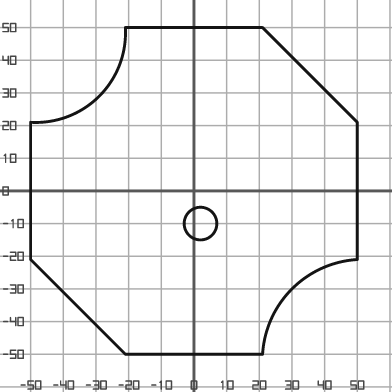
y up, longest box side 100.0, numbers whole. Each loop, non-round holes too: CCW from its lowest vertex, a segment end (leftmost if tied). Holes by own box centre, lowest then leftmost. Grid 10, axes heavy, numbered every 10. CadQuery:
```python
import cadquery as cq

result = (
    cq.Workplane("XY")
    .moveTo(-21.0, -50.0)
    .lineTo(21.0, -50.0)
    .threePointArc((30.0, -30.0), (50.0, -21.0))
    .lineTo(50.0, 21.0)
    .lineTo(21.0, 50.0)
    .lineTo(-21.0, 50.0)
    .threePointArc((-29.0, 29.0), (-50.0, 21.0))
    .lineTo(-50.0, -21.0)
    .close()
    .moveTo(2.0, -10.0)
    .circle(5.0)
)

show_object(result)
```